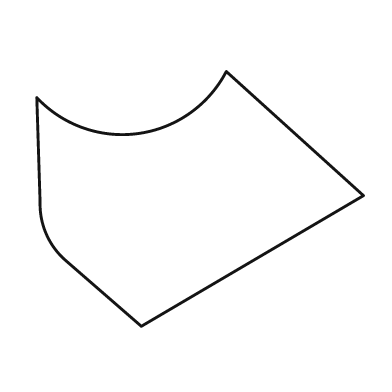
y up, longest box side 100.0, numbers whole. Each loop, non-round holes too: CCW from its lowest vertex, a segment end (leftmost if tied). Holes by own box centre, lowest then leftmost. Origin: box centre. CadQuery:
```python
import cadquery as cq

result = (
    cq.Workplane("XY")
    .moveTo(-18.0, -39.0)
    .lineTo(50.0, 1.0)
    .lineTo(8.0, 39.0)
    .threePointArc((-19.0, 20.0), (-50.0, 31.0))
    .lineTo(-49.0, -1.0)
    .threePointArc((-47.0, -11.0), (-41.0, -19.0))
    .close()
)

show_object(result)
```